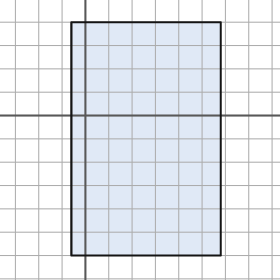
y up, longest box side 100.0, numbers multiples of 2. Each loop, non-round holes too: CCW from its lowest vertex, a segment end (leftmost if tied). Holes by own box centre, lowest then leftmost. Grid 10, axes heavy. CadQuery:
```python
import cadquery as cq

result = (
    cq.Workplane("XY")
    .moveTo(-6.0, -60.0)
    .lineTo(58.0, -60.0)
    .lineTo(58.0, 40.0)
    .lineTo(-6.0, 40.0)
    .close()
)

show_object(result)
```